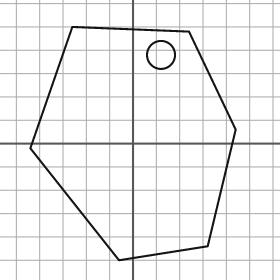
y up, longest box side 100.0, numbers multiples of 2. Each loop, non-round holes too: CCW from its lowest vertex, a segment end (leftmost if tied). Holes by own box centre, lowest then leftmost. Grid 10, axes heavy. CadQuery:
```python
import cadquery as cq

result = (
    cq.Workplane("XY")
    .moveTo(-6.0, -50.0)
    .lineTo(32.0, -44.0)
    .lineTo(44.0, 6.0)
    .lineTo(24.0, 48.0)
    .lineTo(-26.0, 50.0)
    .lineTo(-44.0, -2.0)
    .close()
    .moveTo(12.0, 38.0)
    .circle(6.0)
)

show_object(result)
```